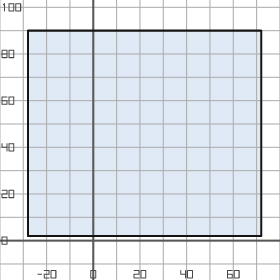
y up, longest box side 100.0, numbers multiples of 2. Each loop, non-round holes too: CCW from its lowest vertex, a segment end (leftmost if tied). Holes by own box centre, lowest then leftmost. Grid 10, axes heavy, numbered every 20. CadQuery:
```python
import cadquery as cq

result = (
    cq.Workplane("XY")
    .moveTo(-28.0, 2.0)
    .lineTo(72.0, 2.0)
    .lineTo(72.0, 90.0)
    .lineTo(-28.0, 90.0)
    .close()
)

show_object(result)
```